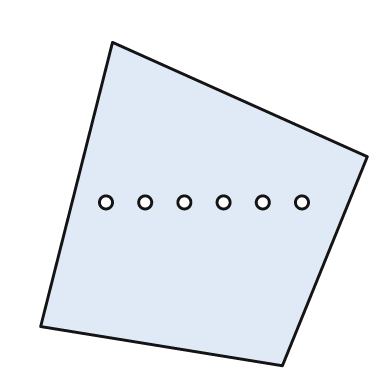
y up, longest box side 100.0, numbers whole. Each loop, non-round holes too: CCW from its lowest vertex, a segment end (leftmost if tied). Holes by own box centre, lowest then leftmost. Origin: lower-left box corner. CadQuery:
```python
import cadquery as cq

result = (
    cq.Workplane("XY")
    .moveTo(74.0, 0.0)
    .lineTo(100.0, 64.0)
    .lineTo(22.0, 99.0)
    .lineTo(0.0, 12.0)
    .close()
    .moveTo(20.0, 50.0)
    .circle(2.0)
    .moveTo(32.0, 50.0)
    .circle(2.0)
    .moveTo(44.0, 50.0)
    .circle(2.0)
    .moveTo(56.0, 50.0)
    .circle(2.0)
    .moveTo(68.0, 50.0)
    .circle(2.0)
    .moveTo(80.0, 50.0)
    .circle(2.0)
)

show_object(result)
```